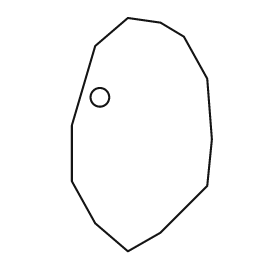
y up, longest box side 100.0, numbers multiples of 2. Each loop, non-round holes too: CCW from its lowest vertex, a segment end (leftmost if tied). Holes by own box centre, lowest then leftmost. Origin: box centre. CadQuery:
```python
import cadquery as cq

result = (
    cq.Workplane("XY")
    .moveTo(-6.0, -50.0)
    .lineTo(8.0, -42.0)
    .lineTo(28.0, -22.0)
    .lineTo(30.0, -2.0)
    .lineTo(28.0, 24.0)
    .lineTo(18.0, 42.0)
    .lineTo(8.0, 48.0)
    .lineTo(-6.0, 50.0)
    .lineTo(-20.0, 38.0)
    .lineTo(-30.0, 4.0)
    .lineTo(-30.0, -20.0)
    .lineTo(-20.0, -38.0)
    .close()
    .moveTo(-18.0, 16.0)
    .circle(4.0)
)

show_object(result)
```